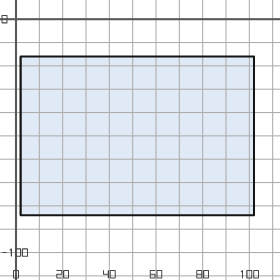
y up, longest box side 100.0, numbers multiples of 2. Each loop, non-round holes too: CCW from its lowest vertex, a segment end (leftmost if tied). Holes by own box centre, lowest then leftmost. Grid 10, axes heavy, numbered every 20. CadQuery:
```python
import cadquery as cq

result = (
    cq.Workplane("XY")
    .moveTo(2.0, -84.0)
    .lineTo(102.0, -84.0)
    .lineTo(102.0, -16.0)
    .lineTo(2.0, -16.0)
    .close()
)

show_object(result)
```